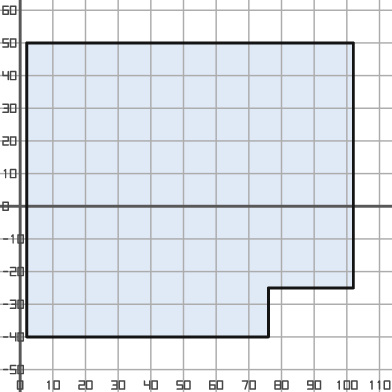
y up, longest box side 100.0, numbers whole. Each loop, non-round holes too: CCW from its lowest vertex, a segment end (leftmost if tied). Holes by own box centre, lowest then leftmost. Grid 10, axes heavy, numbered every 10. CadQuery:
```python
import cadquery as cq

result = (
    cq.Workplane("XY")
    .moveTo(2.0, -40.0)
    .lineTo(76.0, -40.0)
    .lineTo(76.0, -25.0)
    .lineTo(102.0, -25.0)
    .lineTo(102.0, 50.0)
    .lineTo(2.0, 50.0)
    .close()
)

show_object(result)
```